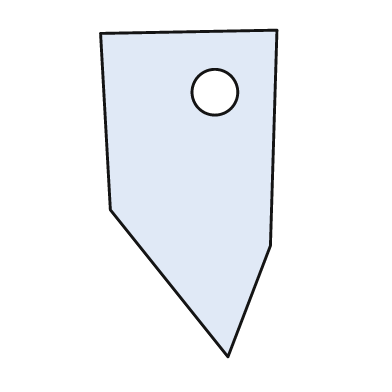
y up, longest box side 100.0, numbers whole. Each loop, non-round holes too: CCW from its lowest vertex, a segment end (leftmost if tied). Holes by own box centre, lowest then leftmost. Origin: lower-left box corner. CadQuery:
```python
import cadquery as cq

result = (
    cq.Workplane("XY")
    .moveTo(39.0, 0.0)
    .lineTo(52.0, 34.0)
    .lineTo(54.0, 100.0)
    .lineTo(0.0, 99.0)
    .lineTo(3.0, 45.0)
    .close()
    .moveTo(35.0, 81.0)
    .circle(7.0)
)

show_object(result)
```